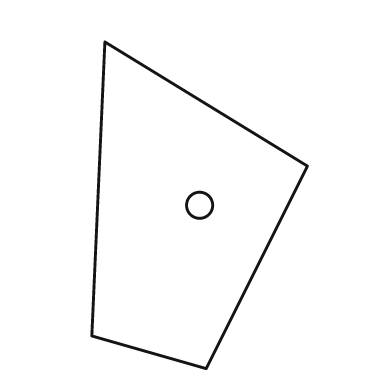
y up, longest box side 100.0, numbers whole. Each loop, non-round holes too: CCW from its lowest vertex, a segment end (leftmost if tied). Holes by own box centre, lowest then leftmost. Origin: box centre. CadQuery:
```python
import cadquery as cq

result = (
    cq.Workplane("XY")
    .moveTo(2.0, -50.0)
    .lineTo(33.0, 12.0)
    .lineTo(-29.0, 50.0)
    .lineTo(-33.0, -40.0)
    .close()
    .moveTo(0.0, 0.0)
    .circle(4.0)
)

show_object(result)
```